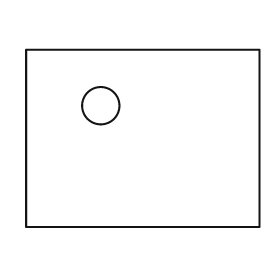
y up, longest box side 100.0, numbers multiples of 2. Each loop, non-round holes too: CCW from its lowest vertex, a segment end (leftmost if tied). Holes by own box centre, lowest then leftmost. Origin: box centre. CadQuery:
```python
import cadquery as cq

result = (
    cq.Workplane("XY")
    .moveTo(-50.0, -38.0)
    .lineTo(50.0, -38.0)
    .lineTo(50.0, 38.0)
    .lineTo(-50.0, 38.0)
    .close()
    .moveTo(-18.0, 14.0)
    .circle(8.0)
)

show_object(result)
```